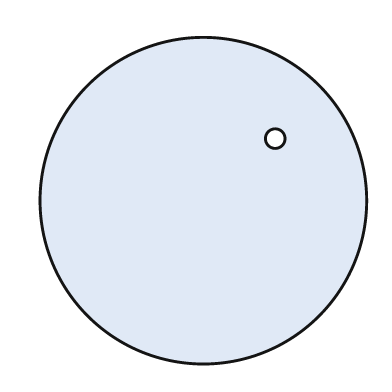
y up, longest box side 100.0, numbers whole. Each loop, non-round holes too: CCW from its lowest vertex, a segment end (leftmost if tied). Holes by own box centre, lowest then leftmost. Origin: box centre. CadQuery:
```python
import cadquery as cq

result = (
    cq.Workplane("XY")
    .moveTo(0.0, 0.0)
    .circle(50.0)
    .moveTo(22.0, 19.0)
    .circle(3.0)
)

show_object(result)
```